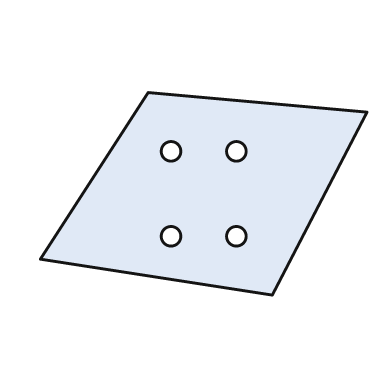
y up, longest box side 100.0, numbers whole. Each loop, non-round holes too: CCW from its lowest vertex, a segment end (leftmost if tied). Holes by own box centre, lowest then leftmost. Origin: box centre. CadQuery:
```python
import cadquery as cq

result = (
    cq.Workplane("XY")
    .moveTo(21.0, -31.0)
    .lineTo(50.0, 25.0)
    .lineTo(-17.0, 31.0)
    .lineTo(-50.0, -20.0)
    .close()
    .moveTo(-10.0, -13.0)
    .circle(3.0)
    .moveTo(10.0, -13.0)
    .circle(3.0)
    .moveTo(-10.0, 13.0)
    .circle(3.0)
    .moveTo(10.0, 13.0)
    .circle(3.0)
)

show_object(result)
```